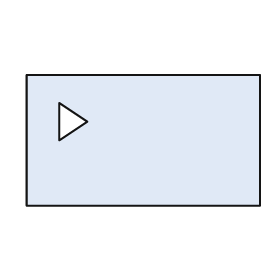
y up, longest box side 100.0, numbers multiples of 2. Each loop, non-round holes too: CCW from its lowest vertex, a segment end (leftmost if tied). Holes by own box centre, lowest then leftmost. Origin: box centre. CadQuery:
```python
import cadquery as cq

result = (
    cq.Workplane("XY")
    .moveTo(-50.0, -28.0)
    .lineTo(50.0, -28.0)
    .lineTo(50.0, 28.0)
    .lineTo(-50.0, 28.0)
    .close()
    .moveTo(-36.0, 0.0)
    .lineTo(-24.0, 8.0)
    .lineTo(-36.0, 16.0)
    .close()
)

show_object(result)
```